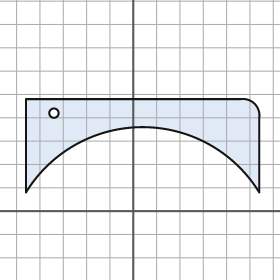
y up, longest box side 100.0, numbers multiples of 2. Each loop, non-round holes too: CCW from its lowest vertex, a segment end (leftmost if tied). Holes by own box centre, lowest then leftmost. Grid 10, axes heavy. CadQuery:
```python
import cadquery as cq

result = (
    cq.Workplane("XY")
    .moveTo(-46.0, 8.0)
    .threePointArc((4.0, 36.0), (54.0, 8.0))
    .lineTo(54.0, 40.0)
    .threePointArc((52.0, 46.0), (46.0, 48.0))
    .lineTo(-46.0, 48.0)
    .close()
    .moveTo(-34.0, 42.0)
    .circle(2.0)
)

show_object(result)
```